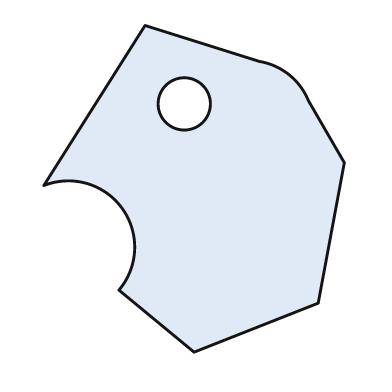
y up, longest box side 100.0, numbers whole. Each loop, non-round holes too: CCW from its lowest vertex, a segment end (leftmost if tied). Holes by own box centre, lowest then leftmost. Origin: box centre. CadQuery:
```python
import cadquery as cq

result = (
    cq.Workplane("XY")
    .moveTo(0.0, -50.0)
    .lineTo(38.0, -35.0)
    .lineTo(46.0, 8.0)
    .lineTo(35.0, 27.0)
    .threePointArc((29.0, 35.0), (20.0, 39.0))
    .lineTo(-15.0, 50.0)
    .lineTo(-46.0, 1.0)
    .threePointArc((-22.0, -6.0), (-23.0, -31.0))
    .close()
    .moveTo(-3.0, 26.0)
    .circle(8.0)
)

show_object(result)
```